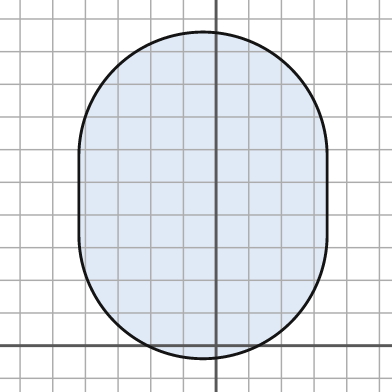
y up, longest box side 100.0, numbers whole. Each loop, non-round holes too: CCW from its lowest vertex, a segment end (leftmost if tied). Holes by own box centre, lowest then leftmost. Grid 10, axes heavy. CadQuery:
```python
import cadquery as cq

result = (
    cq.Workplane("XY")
    .moveTo(-42.0, 34.0)
    .threePointArc((-4.0, -4.0), (34.0, 34.0))
    .lineTo(34.0, 58.0)
    .threePointArc((-4.0, 96.0), (-42.0, 58.0))
    .close()
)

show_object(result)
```